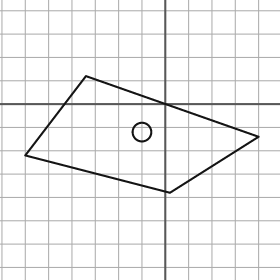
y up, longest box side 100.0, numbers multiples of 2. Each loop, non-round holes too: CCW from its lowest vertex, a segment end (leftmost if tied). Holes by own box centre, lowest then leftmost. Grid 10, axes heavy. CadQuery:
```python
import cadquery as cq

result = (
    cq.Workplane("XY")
    .moveTo(2.0, -38.0)
    .lineTo(40.0, -14.0)
    .lineTo(-34.0, 12.0)
    .lineTo(-60.0, -22.0)
    .close()
    .moveTo(-10.0, -12.0)
    .circle(4.0)
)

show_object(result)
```